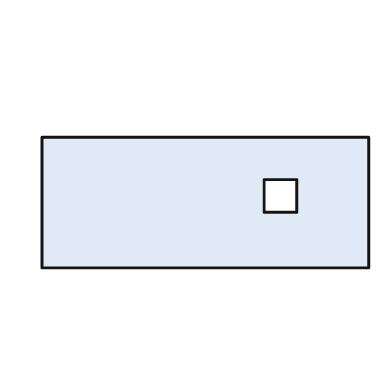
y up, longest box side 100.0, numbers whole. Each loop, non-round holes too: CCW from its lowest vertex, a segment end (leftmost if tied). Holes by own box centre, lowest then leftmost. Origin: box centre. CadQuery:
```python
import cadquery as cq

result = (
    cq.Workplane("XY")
    .moveTo(-50.0, -20.0)
    .lineTo(50.0, -20.0)
    .lineTo(50.0, 20.0)
    .lineTo(-50.0, 20.0)
    .close()
    .moveTo(18.0, -3.0)
    .lineTo(28.0, -3.0)
    .lineTo(28.0, 7.0)
    .lineTo(18.0, 7.0)
    .close()
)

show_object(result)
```